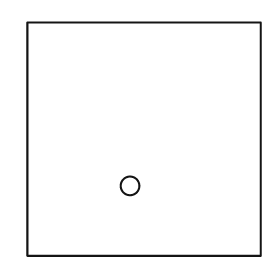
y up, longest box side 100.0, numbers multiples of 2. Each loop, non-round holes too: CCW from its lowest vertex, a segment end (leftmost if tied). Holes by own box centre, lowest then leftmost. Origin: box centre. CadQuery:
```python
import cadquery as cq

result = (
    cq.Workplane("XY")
    .moveTo(-50.0, -50.0)
    .lineTo(50.0, -50.0)
    .lineTo(50.0, 50.0)
    .lineTo(-50.0, 50.0)
    .close()
    .moveTo(-6.0, -20.0)
    .circle(4.0)
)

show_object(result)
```